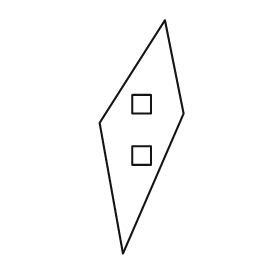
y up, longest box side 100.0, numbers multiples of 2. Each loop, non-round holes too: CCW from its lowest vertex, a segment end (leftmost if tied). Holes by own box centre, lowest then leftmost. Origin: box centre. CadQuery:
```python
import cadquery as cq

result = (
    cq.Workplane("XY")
    .moveTo(-8.0, -50.0)
    .lineTo(18.0, 10.0)
    .lineTo(10.0, 50.0)
    .lineTo(-18.0, 6.0)
    .close()
    .moveTo(-4.0, -12.0)
    .lineTo(4.0, -12.0)
    .lineTo(4.0, -4.0)
    .lineTo(-4.0, -4.0)
    .close()
    .moveTo(-4.0, 10.0)
    .lineTo(4.0, 10.0)
    .lineTo(4.0, 18.0)
    .lineTo(-4.0, 18.0)
    .close()
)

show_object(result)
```